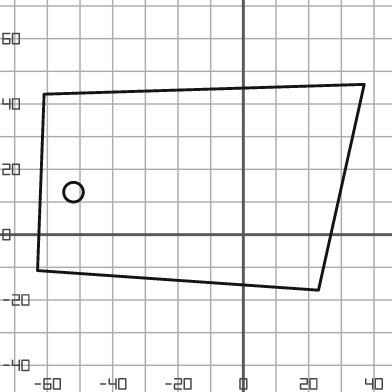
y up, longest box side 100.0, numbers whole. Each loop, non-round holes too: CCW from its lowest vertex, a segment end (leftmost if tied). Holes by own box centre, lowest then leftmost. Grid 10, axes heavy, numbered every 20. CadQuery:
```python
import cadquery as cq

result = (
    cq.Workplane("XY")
    .moveTo(23.0, -17.0)
    .lineTo(37.0, 46.0)
    .lineTo(-61.0, 43.0)
    .lineTo(-63.0, -11.0)
    .close()
    .moveTo(-52.0, 13.0)
    .circle(3.0)
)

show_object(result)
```